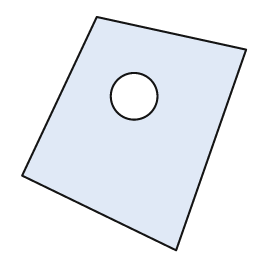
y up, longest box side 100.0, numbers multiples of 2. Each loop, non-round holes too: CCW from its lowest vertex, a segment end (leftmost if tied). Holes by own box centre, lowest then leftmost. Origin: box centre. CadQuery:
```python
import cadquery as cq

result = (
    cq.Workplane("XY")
    .moveTo(18.0, -50.0)
    .lineTo(48.0, 36.0)
    .lineTo(-16.0, 50.0)
    .lineTo(-48.0, -18.0)
    .close()
    .moveTo(0.0, 16.0)
    .circle(10.0)
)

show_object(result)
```